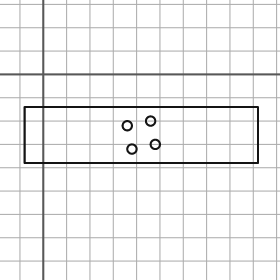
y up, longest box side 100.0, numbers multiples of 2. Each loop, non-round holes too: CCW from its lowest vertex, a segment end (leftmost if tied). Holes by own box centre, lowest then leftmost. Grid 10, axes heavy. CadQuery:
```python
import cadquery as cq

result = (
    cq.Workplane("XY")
    .moveTo(-8.0, -38.0)
    .lineTo(92.0, -38.0)
    .lineTo(92.0, -14.0)
    .lineTo(-8.0, -14.0)
    .close()
    .moveTo(38.0, -32.0)
    .circle(2.0)
    .moveTo(48.0, -30.0)
    .circle(2.0)
    .moveTo(36.0, -22.0)
    .circle(2.0)
    .moveTo(46.0, -20.0)
    .circle(2.0)
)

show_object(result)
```